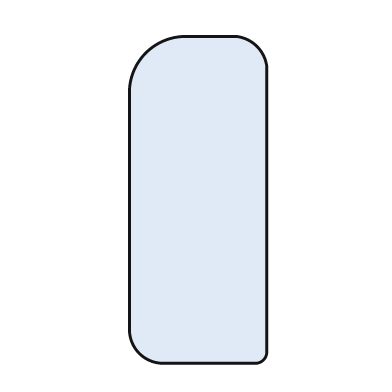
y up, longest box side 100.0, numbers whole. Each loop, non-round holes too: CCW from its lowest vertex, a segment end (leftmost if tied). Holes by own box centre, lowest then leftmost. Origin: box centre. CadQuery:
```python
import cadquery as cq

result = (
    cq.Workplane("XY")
    .moveTo(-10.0, -50.0)
    .lineTo(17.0, -50.0)
    .threePointArc((20.0, -49.0), (21.0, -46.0))
    .lineTo(21.0, 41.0)
    .threePointArc((18.0, 47.0), (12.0, 50.0))
    .lineTo(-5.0, 50.0)
    .threePointArc((-16.0, 45.0), (-21.0, 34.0))
    .lineTo(-21.0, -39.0)
    .threePointArc((-18.0, -47.0), (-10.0, -50.0))
    .close()
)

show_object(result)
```